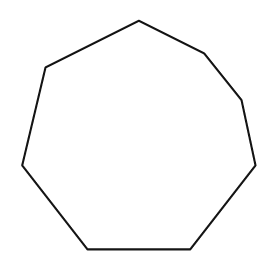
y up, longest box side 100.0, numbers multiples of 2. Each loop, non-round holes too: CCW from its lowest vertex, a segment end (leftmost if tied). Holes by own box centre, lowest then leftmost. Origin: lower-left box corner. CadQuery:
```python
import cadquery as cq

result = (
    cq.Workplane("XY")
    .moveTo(28.0, 0.0)
    .lineTo(72.0, 0.0)
    .lineTo(100.0, 36.0)
    .lineTo(94.0, 64.0)
    .lineTo(78.0, 84.0)
    .lineTo(50.0, 98.0)
    .lineTo(10.0, 78.0)
    .lineTo(0.0, 36.0)
    .close()
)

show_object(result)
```